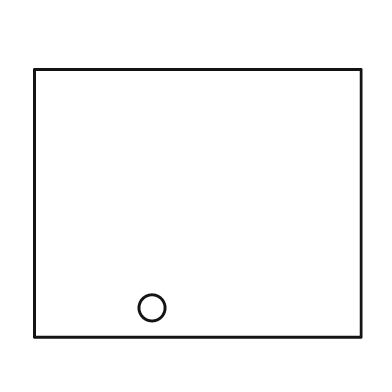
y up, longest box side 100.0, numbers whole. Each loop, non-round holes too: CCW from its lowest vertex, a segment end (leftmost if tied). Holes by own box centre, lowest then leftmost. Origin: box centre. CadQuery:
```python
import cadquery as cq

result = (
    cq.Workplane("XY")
    .moveTo(-50.0, -41.0)
    .lineTo(50.0, -41.0)
    .lineTo(50.0, 41.0)
    .lineTo(-50.0, 41.0)
    .close()
    .moveTo(-14.0, -32.0)
    .circle(4.0)
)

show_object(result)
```